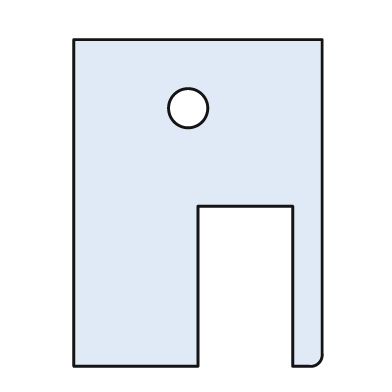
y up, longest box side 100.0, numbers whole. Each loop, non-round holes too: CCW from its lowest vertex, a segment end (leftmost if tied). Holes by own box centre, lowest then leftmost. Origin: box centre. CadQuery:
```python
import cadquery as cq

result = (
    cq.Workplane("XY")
    .moveTo(-38.0, -50.0)
    .lineTo(0.0, -50.0)
    .lineTo(0.0, -1.0)
    .lineTo(29.0, -1.0)
    .lineTo(29.0, -50.0)
    .lineTo(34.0, -50.0)
    .threePointArc((37.0, -49.0), (38.0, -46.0))
    .lineTo(38.0, 50.0)
    .lineTo(-38.0, 50.0)
    .close()
    .moveTo(-3.0, 29.0)
    .circle(6.0)
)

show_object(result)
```